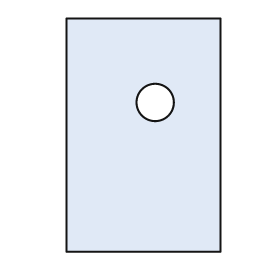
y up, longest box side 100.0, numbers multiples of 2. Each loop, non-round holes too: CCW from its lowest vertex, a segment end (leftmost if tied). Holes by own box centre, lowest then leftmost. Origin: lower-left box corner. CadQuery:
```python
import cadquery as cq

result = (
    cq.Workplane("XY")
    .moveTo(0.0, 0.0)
    .lineTo(66.0, 0.0)
    .lineTo(66.0, 100.0)
    .lineTo(0.0, 100.0)
    .close()
    .moveTo(38.0, 64.0)
    .circle(8.0)
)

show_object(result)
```